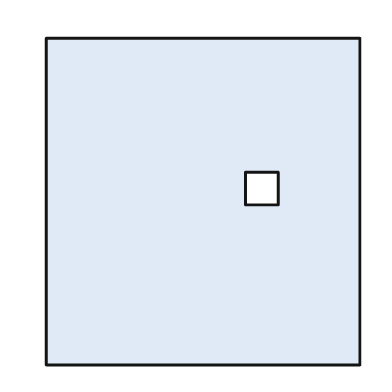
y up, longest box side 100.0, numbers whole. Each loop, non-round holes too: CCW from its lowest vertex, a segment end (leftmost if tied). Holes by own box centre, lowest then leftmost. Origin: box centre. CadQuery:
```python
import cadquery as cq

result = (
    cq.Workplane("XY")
    .moveTo(-48.0, -50.0)
    .lineTo(48.0, -50.0)
    .lineTo(48.0, 50.0)
    .lineTo(-48.0, 50.0)
    .close()
    .moveTo(13.0, -1.0)
    .lineTo(23.0, -1.0)
    .lineTo(23.0, 9.0)
    .lineTo(13.0, 9.0)
    .close()
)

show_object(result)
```